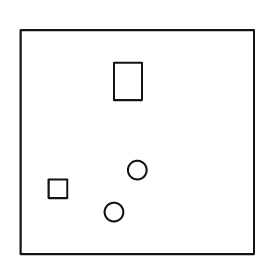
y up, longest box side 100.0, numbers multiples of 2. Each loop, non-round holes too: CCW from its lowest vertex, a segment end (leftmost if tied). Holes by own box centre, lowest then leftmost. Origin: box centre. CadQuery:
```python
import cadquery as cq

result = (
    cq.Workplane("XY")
    .moveTo(-50.0, -48.0)
    .lineTo(50.0, -48.0)
    .lineTo(50.0, 48.0)
    .lineTo(-50.0, 48.0)
    .close()
    .moveTo(-10.0, -30.0)
    .circle(4.0)
    .moveTo(-38.0, -24.0)
    .lineTo(-30.0, -24.0)
    .lineTo(-30.0, -16.0)
    .lineTo(-38.0, -16.0)
    .close()
    .moveTo(0.0, -12.0)
    .circle(4.0)
    .moveTo(-10.0, 18.0)
    .lineTo(2.0, 18.0)
    .lineTo(2.0, 34.0)
    .lineTo(-10.0, 34.0)
    .close()
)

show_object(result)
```